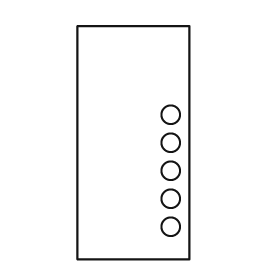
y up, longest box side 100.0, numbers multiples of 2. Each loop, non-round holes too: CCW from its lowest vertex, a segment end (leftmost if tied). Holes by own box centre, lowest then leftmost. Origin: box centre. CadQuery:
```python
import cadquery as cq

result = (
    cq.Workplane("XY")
    .moveTo(-24.0, -50.0)
    .lineTo(24.0, -50.0)
    .lineTo(24.0, 50.0)
    .lineTo(-24.0, 50.0)
    .close()
    .moveTo(16.0, -36.0)
    .circle(4.0)
    .moveTo(16.0, -24.0)
    .circle(4.0)
    .moveTo(16.0, -12.0)
    .circle(4.0)
    .moveTo(16.0, 0.0)
    .circle(4.0)
    .moveTo(16.0, 12.0)
    .circle(4.0)
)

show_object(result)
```